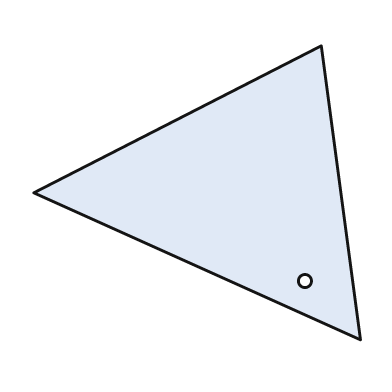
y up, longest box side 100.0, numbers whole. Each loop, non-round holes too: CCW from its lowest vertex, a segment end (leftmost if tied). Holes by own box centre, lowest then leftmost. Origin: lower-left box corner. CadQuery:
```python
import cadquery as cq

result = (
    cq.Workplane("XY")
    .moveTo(100.0, 0.0)
    .lineTo(88.0, 90.0)
    .lineTo(0.0, 45.0)
    .close()
    .moveTo(83.0, 18.0)
    .circle(2.0)
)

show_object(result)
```